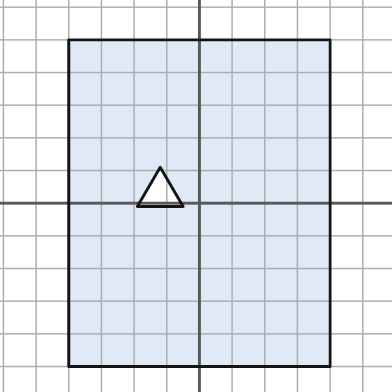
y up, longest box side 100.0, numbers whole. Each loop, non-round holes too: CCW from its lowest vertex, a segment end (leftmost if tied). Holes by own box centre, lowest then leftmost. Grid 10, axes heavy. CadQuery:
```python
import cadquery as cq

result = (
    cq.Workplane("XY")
    .moveTo(-40.0, -50.0)
    .lineTo(40.0, -50.0)
    .lineTo(40.0, 50.0)
    .lineTo(-40.0, 50.0)
    .close()
    .moveTo(-19.0, -1.0)
    .lineTo(-5.0, -1.0)
    .lineTo(-12.0, 11.0)
    .close()
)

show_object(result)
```